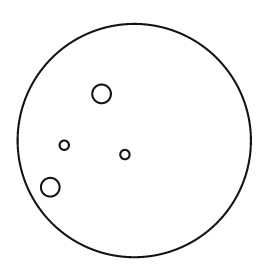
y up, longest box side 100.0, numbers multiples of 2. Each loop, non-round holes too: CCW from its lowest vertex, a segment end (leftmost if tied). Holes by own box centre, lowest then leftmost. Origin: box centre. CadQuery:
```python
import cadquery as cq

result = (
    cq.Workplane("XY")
    .moveTo(0.0, 0.0)
    .circle(50.0)
    .moveTo(-36.0, -20.0)
    .circle(4.0)
    .moveTo(-4.0, -6.0)
    .circle(2.0)
    .moveTo(-30.0, -2.0)
    .circle(2.0)
    .moveTo(-14.0, 20.0)
    .circle(4.0)
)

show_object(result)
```